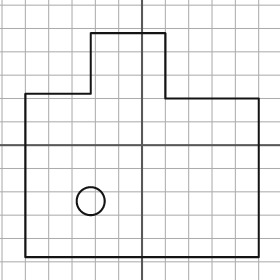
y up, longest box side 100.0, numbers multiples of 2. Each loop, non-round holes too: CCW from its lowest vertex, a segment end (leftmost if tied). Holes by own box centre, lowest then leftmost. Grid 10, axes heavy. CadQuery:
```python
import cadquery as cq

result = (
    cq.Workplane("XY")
    .moveTo(-50.0, -48.0)
    .lineTo(50.0, -48.0)
    .lineTo(50.0, 20.0)
    .lineTo(10.0, 20.0)
    .lineTo(10.0, 48.0)
    .lineTo(-22.0, 48.0)
    .lineTo(-22.0, 22.0)
    .lineTo(-50.0, 22.0)
    .close()
    .moveTo(-22.0, -24.0)
    .circle(6.0)
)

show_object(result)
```